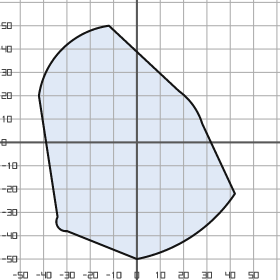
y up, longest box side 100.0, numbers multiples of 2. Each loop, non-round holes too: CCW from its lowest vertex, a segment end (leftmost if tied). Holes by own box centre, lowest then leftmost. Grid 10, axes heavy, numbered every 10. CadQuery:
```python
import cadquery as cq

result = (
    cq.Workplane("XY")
    .moveTo(0.0, -50.0)
    .threePointArc((24.0, -40.0), (42.0, -22.0))
    .lineTo(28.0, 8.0)
    .threePointArc((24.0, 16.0), (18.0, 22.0))
    .lineTo(-12.0, 50.0)
    .threePointArc((-32.0, 40.0), (-42.0, 20.0))
    .lineTo(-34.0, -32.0)
    .threePointArc((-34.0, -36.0), (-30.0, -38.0))
    .close()
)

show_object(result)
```